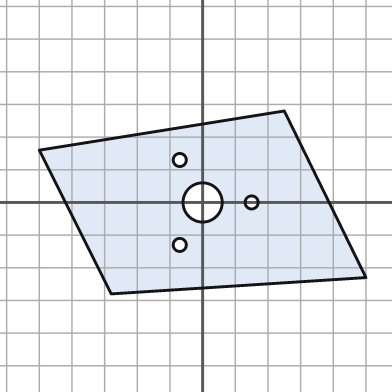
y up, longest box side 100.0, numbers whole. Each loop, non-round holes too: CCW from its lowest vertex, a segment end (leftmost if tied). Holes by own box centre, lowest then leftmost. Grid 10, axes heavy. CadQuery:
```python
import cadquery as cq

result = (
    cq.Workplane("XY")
    .moveTo(-28.0, -28.0)
    .lineTo(50.0, -23.0)
    .lineTo(25.0, 28.0)
    .lineTo(-50.0, 16.0)
    .close()
    .moveTo(-7.0, -13.0)
    .circle(2.0)
    .moveTo(0.0, 0.0)
    .circle(6.0)
    .moveTo(15.0, 0.0)
    .circle(2.0)
    .moveTo(-7.0, 13.0)
    .circle(2.0)
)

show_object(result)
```